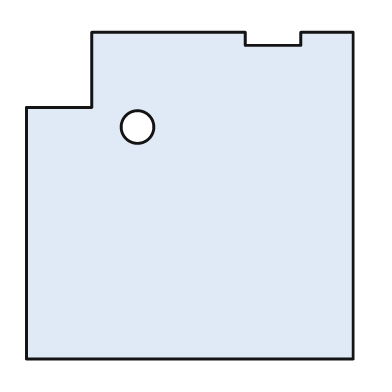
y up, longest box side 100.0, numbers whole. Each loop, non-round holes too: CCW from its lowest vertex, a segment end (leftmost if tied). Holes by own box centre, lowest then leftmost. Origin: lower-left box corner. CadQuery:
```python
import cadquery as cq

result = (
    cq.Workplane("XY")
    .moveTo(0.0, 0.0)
    .lineTo(100.0, 0.0)
    .lineTo(100.0, 100.0)
    .lineTo(84.0, 100.0)
    .lineTo(84.0, 96.0)
    .lineTo(67.0, 96.0)
    .lineTo(67.0, 100.0)
    .lineTo(20.0, 100.0)
    .lineTo(20.0, 77.0)
    .lineTo(0.0, 77.0)
    .close()
    .moveTo(34.0, 71.0)
    .circle(5.0)
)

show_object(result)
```